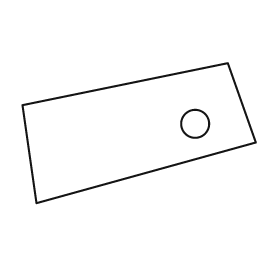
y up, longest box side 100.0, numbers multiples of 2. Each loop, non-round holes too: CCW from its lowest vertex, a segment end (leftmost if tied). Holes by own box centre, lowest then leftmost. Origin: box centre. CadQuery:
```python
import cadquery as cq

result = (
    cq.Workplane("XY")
    .moveTo(-44.0, -30.0)
    .lineTo(50.0, -4.0)
    .lineTo(38.0, 30.0)
    .lineTo(-50.0, 12.0)
    .close()
    .moveTo(24.0, 4.0)
    .circle(6.0)
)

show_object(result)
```